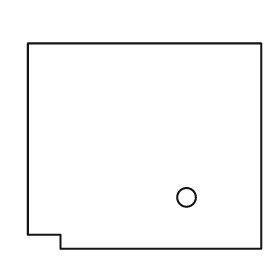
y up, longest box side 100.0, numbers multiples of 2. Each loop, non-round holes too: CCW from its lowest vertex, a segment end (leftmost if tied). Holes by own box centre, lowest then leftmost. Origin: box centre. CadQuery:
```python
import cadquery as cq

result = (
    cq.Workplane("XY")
    .moveTo(-36.0, -44.0)
    .lineTo(50.0, -44.0)
    .lineTo(50.0, 44.0)
    .lineTo(-50.0, 44.0)
    .lineTo(-50.0, -38.0)
    .lineTo(-36.0, -38.0)
    .close()
    .moveTo(18.0, -22.0)
    .circle(4.0)
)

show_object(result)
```